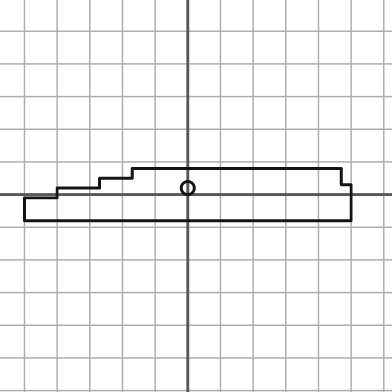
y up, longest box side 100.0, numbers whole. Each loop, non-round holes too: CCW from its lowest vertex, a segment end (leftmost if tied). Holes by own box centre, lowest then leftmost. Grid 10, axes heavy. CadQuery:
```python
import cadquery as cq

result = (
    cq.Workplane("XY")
    .moveTo(-50.0, -8.0)
    .lineTo(50.0, -8.0)
    .lineTo(50.0, 3.0)
    .lineTo(47.0, 3.0)
    .lineTo(47.0, 8.0)
    .lineTo(-17.0, 8.0)
    .lineTo(-17.0, 5.0)
    .lineTo(-27.0, 5.0)
    .lineTo(-27.0, 2.0)
    .lineTo(-40.0, 2.0)
    .lineTo(-40.0, -1.0)
    .lineTo(-50.0, -1.0)
    .close()
    .moveTo(0.0, 2.0)
    .circle(2.0)
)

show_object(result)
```